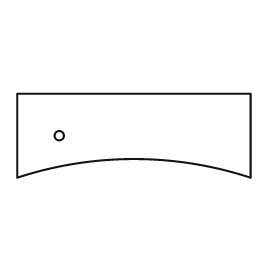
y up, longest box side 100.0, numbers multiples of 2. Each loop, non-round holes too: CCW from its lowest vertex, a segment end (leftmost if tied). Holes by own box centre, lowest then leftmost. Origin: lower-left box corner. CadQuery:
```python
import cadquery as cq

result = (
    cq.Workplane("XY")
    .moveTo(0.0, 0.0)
    .threePointArc((50.0, 8.0), (100.0, 0.0))
    .lineTo(100.0, 36.0)
    .lineTo(0.0, 36.0)
    .close()
    .moveTo(18.0, 18.0)
    .circle(2.0)
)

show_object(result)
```